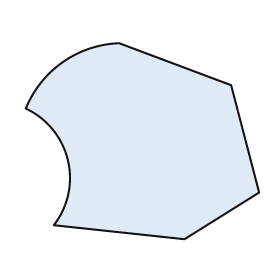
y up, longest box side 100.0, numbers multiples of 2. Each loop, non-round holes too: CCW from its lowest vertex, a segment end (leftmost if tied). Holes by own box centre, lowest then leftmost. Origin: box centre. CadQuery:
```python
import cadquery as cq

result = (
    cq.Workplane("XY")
    .moveTo(18.0, -42.0)
    .lineTo(50.0, -22.0)
    .lineTo(38.0, 24.0)
    .lineTo(-10.0, 42.0)
    .threePointArc((-34.0, 34.0), (-50.0, 14.0))
    .threePointArc((-32.0, -8.0), (-38.0, -36.0))
    .close()
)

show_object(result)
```